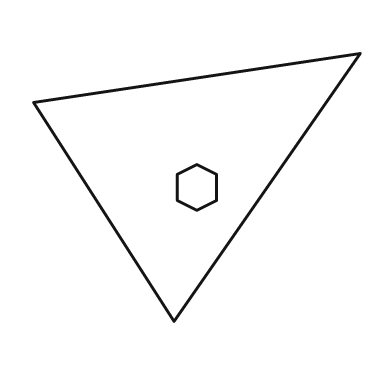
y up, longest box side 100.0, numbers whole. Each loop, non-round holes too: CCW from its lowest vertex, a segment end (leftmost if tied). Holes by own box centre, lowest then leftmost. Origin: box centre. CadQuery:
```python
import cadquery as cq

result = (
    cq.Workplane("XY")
    .moveTo(-7.0, -41.0)
    .lineTo(50.0, 41.0)
    .lineTo(-50.0, 26.0)
    .close()
    .moveTo(0.0, -7.0)
    .lineTo(6.0, -4.0)
    .lineTo(6.0, 4.0)
    .lineTo(0.0, 7.0)
    .lineTo(-6.0, 4.0)
    .lineTo(-6.0, -4.0)
    .close()
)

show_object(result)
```